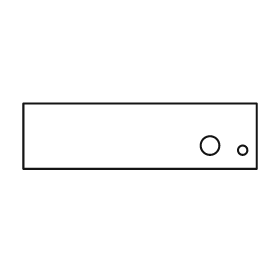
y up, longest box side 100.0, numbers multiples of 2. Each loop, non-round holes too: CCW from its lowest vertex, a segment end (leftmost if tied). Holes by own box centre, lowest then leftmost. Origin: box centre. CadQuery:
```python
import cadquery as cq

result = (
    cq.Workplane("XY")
    .moveTo(-50.0, -14.0)
    .lineTo(50.0, -14.0)
    .lineTo(50.0, 14.0)
    .lineTo(-50.0, 14.0)
    .close()
    .moveTo(44.0, -6.0)
    .circle(2.0)
    .moveTo(30.0, -4.0)
    .circle(4.0)
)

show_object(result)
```